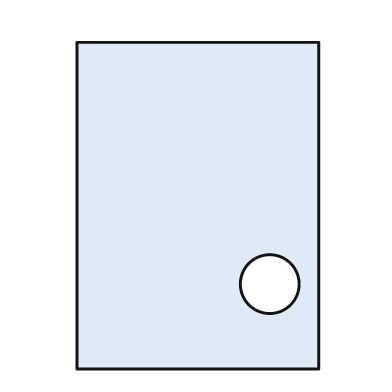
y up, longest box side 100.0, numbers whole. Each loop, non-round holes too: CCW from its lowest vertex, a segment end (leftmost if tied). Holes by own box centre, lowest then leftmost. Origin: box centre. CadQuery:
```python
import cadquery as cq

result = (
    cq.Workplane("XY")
    .moveTo(-37.0, -50.0)
    .lineTo(37.0, -50.0)
    .lineTo(37.0, 50.0)
    .lineTo(-37.0, 50.0)
    .close()
    .moveTo(22.0, -24.0)
    .circle(9.0)
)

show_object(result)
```